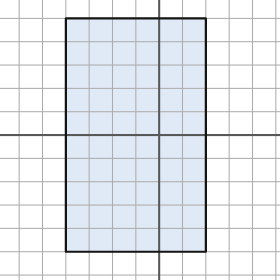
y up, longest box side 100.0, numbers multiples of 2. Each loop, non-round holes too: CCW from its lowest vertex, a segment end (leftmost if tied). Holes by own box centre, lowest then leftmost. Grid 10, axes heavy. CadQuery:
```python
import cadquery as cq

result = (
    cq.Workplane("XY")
    .moveTo(-40.0, -50.0)
    .lineTo(20.0, -50.0)
    .lineTo(20.0, 50.0)
    .lineTo(-40.0, 50.0)
    .close()
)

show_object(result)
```